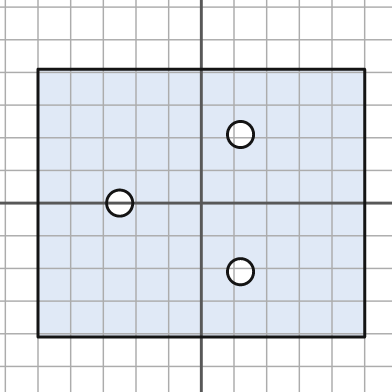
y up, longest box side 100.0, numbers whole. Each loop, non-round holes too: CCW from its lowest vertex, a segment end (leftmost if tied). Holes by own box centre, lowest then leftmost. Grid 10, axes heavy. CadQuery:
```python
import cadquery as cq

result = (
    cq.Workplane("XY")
    .moveTo(-50.0, -41.0)
    .lineTo(50.0, -41.0)
    .lineTo(50.0, 41.0)
    .lineTo(-50.0, 41.0)
    .close()
    .moveTo(12.0, -21.0)
    .circle(4.0)
    .moveTo(-25.0, 0.0)
    .circle(4.0)
    .moveTo(12.0, 21.0)
    .circle(4.0)
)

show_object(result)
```